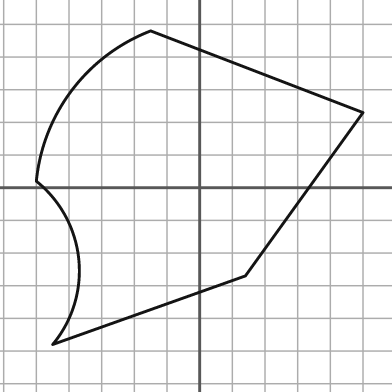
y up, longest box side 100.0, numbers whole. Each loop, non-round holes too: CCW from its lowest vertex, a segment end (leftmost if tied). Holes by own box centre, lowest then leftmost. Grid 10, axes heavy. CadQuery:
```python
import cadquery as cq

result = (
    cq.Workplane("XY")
    .moveTo(-45.0, -48.0)
    .lineTo(14.0, -27.0)
    .lineTo(50.0, 23.0)
    .lineTo(-15.0, 48.0)
    .threePointArc((-39.0, 30.0), (-50.0, 2.0))
    .threePointArc((-37.0, -22.0), (-45.0, -48.0))
    .close()
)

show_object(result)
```